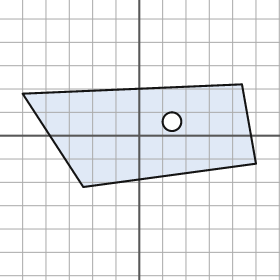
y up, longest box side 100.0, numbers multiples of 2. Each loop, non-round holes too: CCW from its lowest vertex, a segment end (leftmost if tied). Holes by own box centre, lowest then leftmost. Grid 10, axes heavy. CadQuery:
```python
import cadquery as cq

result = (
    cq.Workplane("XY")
    .moveTo(-24.0, -22.0)
    .lineTo(50.0, -12.0)
    .lineTo(44.0, 22.0)
    .lineTo(-50.0, 18.0)
    .close()
    .moveTo(14.0, 6.0)
    .circle(4.0)
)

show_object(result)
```